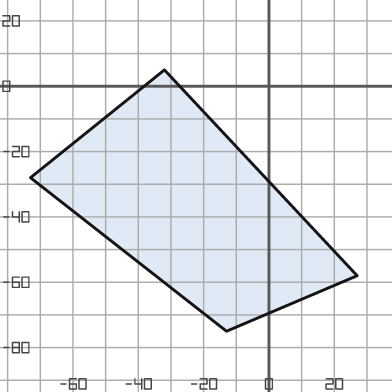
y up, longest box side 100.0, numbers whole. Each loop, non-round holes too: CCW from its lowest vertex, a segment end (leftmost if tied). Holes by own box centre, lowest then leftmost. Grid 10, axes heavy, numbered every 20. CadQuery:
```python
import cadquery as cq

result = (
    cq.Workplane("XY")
    .moveTo(-13.0, -75.0)
    .lineTo(27.0, -58.0)
    .lineTo(-32.0, 5.0)
    .lineTo(-73.0, -28.0)
    .close()
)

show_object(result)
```